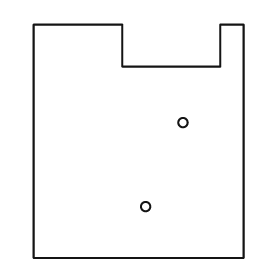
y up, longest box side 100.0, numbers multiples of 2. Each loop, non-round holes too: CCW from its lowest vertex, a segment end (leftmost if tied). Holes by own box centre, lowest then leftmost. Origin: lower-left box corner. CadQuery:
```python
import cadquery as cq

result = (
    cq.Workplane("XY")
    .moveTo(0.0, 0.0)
    .lineTo(90.0, 0.0)
    .lineTo(90.0, 100.0)
    .lineTo(80.0, 100.0)
    .lineTo(80.0, 82.0)
    .lineTo(38.0, 82.0)
    .lineTo(38.0, 100.0)
    .lineTo(0.0, 100.0)
    .close()
    .moveTo(48.0, 22.0)
    .circle(2.0)
    .moveTo(64.0, 58.0)
    .circle(2.0)
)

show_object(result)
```